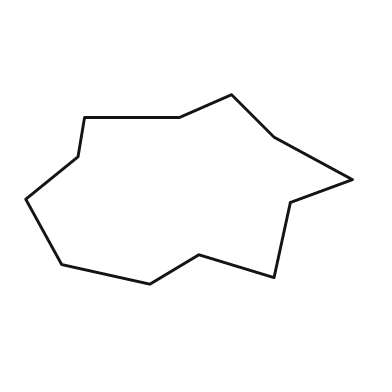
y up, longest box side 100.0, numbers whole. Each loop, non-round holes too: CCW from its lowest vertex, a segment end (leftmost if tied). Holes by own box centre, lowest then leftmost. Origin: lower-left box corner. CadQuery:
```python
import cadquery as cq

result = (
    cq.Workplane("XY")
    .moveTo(38.0, 0.0)
    .lineTo(53.0, 9.0)
    .lineTo(76.0, 2.0)
    .lineTo(81.0, 25.0)
    .lineTo(100.0, 32.0)
    .lineTo(76.0, 45.0)
    .lineTo(63.0, 58.0)
    .lineTo(47.0, 51.0)
    .lineTo(18.0, 51.0)
    .lineTo(16.0, 39.0)
    .lineTo(0.0, 26.0)
    .lineTo(11.0, 6.0)
    .close()
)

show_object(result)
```